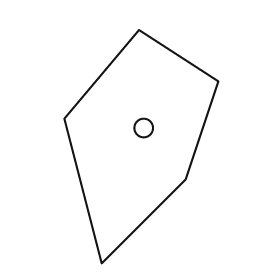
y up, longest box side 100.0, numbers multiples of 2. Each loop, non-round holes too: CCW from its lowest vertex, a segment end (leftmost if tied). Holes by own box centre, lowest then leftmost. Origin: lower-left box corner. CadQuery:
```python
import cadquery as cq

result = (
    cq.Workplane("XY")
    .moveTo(16.0, 0.0)
    .lineTo(52.0, 36.0)
    .lineTo(66.0, 78.0)
    .lineTo(32.0, 100.0)
    .lineTo(0.0, 62.0)
    .close()
    .moveTo(34.0, 58.0)
    .circle(4.0)
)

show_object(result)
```